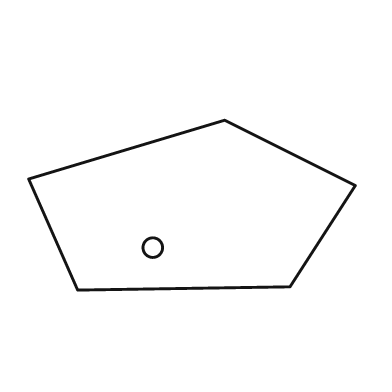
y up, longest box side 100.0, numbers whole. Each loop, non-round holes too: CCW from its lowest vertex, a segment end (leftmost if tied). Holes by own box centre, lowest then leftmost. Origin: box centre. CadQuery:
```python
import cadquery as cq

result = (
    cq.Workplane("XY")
    .moveTo(-35.0, -26.0)
    .lineTo(30.0, -25.0)
    .lineTo(50.0, 6.0)
    .lineTo(10.0, 26.0)
    .lineTo(-50.0, 8.0)
    .close()
    .moveTo(-12.0, -13.0)
    .circle(3.0)
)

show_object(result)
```